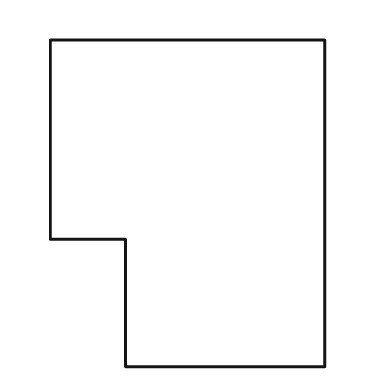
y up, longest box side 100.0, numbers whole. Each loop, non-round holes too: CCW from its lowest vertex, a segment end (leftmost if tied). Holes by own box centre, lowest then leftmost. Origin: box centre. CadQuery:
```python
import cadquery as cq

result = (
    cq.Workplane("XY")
    .moveTo(-19.0, -50.0)
    .lineTo(42.0, -50.0)
    .lineTo(42.0, 50.0)
    .lineTo(-42.0, 50.0)
    .lineTo(-42.0, -11.0)
    .lineTo(-19.0, -11.0)
    .close()
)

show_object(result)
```